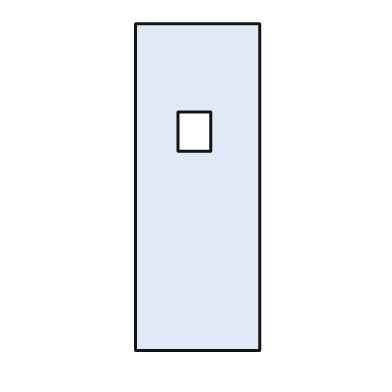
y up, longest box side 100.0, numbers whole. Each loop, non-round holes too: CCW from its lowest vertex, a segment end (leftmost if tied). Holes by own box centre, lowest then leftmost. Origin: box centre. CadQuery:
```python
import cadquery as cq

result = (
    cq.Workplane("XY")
    .moveTo(-19.0, -50.0)
    .lineTo(19.0, -50.0)
    .lineTo(19.0, 50.0)
    .lineTo(-19.0, 50.0)
    .close()
    .moveTo(-6.0, 11.0)
    .lineTo(4.0, 11.0)
    .lineTo(4.0, 23.0)
    .lineTo(-6.0, 23.0)
    .close()
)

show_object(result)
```